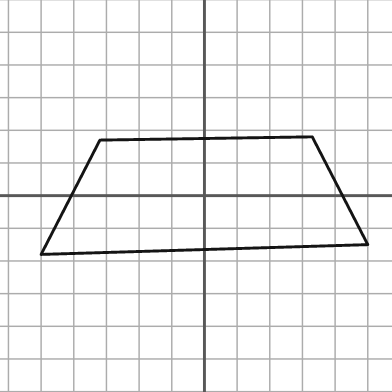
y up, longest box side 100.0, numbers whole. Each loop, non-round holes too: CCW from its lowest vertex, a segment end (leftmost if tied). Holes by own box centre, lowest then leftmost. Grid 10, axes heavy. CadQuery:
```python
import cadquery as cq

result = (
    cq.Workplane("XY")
    .moveTo(-50.0, -18.0)
    .lineTo(50.0, -15.0)
    .lineTo(33.0, 18.0)
    .lineTo(-32.0, 17.0)
    .close()
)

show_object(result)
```